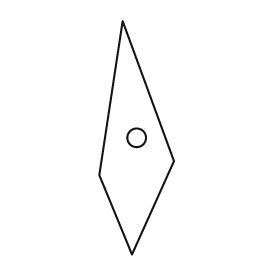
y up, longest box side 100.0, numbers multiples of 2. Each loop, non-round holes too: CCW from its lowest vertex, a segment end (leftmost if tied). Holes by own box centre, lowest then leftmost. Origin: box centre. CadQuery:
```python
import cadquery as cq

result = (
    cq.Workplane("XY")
    .moveTo(-2.0, -50.0)
    .lineTo(16.0, -10.0)
    .lineTo(-6.0, 50.0)
    .lineTo(-16.0, -16.0)
    .close()
    .moveTo(0.0, 0.0)
    .circle(4.0)
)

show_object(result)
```